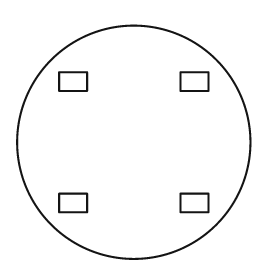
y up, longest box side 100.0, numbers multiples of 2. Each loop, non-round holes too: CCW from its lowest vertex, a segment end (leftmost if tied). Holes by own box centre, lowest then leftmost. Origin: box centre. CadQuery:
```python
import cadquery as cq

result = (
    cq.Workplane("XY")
    .moveTo(0.0, 0.0)
    .circle(50.0)
    .moveTo(-32.0, -30.0)
    .lineTo(-20.0, -30.0)
    .lineTo(-20.0, -22.0)
    .lineTo(-32.0, -22.0)
    .close()
    .moveTo(20.0, -30.0)
    .lineTo(32.0, -30.0)
    .lineTo(32.0, -22.0)
    .lineTo(20.0, -22.0)
    .close()
    .moveTo(-32.0, 22.0)
    .lineTo(-20.0, 22.0)
    .lineTo(-20.0, 30.0)
    .lineTo(-32.0, 30.0)
    .close()
    .moveTo(20.0, 22.0)
    .lineTo(32.0, 22.0)
    .lineTo(32.0, 30.0)
    .lineTo(20.0, 30.0)
    .close()
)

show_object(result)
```